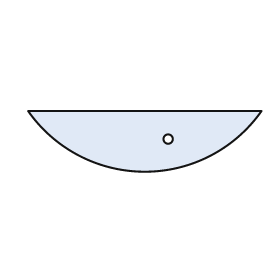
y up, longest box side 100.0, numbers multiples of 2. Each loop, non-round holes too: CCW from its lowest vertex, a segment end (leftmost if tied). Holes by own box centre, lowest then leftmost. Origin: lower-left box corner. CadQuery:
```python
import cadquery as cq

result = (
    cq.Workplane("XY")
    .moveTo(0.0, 26.0)
    .threePointArc((50.0, 0.0), (100.0, 26.0))
    .close()
    .moveTo(60.0, 14.0)
    .circle(2.0)
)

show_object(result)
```